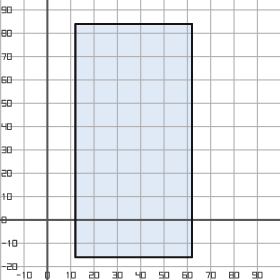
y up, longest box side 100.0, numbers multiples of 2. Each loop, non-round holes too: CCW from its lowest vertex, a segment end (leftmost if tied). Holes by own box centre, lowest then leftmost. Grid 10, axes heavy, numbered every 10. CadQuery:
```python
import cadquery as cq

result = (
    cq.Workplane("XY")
    .moveTo(12.0, -16.0)
    .lineTo(62.0, -16.0)
    .lineTo(62.0, 84.0)
    .lineTo(12.0, 84.0)
    .close()
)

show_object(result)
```